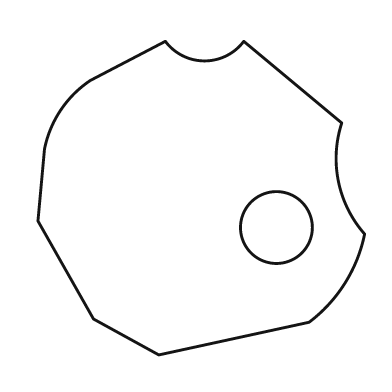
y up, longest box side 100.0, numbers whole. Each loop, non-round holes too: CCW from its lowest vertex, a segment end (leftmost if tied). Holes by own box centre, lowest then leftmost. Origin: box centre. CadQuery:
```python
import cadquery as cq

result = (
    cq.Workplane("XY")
    .moveTo(-13.0, -48.0)
    .lineTo(33.0, -38.0)
    .threePointArc((44.0, -26.0), (50.0, -11.0))
    .threePointArc((42.0, 5.0), (43.0, 23.0))
    .lineTo(13.0, 48.0)
    .threePointArc((1.0, 42.0), (-11.0, 48.0))
    .lineTo(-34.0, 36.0)
    .threePointArc((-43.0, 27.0), (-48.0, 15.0))
    .lineTo(-50.0, -7.0)
    .lineTo(-33.0, -37.0)
    .close()
    .moveTo(23.0, -9.0)
    .circle(11.0)
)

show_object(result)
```